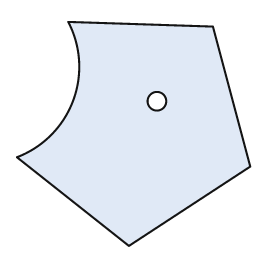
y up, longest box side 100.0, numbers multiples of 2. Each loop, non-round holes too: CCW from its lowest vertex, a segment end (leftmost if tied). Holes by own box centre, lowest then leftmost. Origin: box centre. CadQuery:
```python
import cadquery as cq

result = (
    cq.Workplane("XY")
    .moveTo(-2.0, -48.0)
    .lineTo(50.0, -14.0)
    .lineTo(34.0, 46.0)
    .lineTo(-28.0, 48.0)
    .threePointArc((-26.0, 14.0), (-50.0, -10.0))
    .close()
    .moveTo(10.0, 14.0)
    .circle(4.0)
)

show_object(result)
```